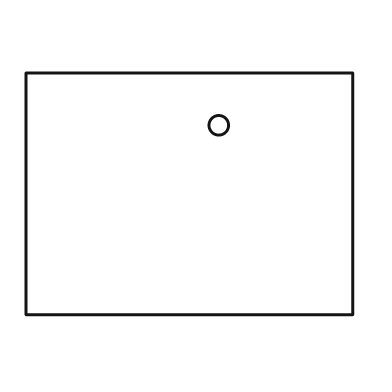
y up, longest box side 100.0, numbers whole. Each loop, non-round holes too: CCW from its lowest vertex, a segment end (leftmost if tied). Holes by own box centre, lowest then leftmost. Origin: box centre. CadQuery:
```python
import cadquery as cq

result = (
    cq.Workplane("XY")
    .moveTo(-50.0, -37.0)
    .lineTo(50.0, -37.0)
    .lineTo(50.0, 37.0)
    .lineTo(-50.0, 37.0)
    .close()
    .moveTo(9.0, 21.0)
    .circle(3.0)
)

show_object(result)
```